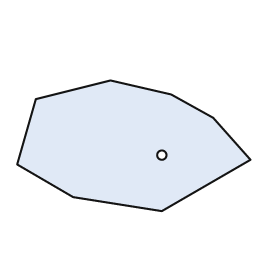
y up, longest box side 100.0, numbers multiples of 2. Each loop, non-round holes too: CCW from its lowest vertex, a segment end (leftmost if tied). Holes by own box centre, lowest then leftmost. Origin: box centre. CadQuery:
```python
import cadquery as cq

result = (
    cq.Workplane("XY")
    .moveTo(12.0, -28.0)
    .lineTo(50.0, -6.0)
    .lineTo(34.0, 12.0)
    .lineTo(16.0, 22.0)
    .lineTo(-10.0, 28.0)
    .lineTo(-42.0, 20.0)
    .lineTo(-50.0, -8.0)
    .lineTo(-26.0, -22.0)
    .close()
    .moveTo(12.0, -4.0)
    .circle(2.0)
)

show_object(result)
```